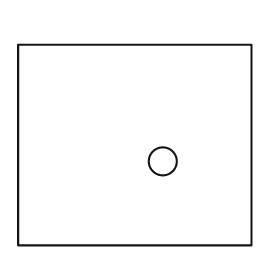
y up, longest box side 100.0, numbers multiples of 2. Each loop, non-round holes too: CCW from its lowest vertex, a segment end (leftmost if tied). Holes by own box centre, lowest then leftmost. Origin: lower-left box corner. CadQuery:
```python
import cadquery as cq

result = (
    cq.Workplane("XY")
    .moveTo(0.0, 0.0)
    .lineTo(100.0, 0.0)
    .lineTo(100.0, 86.0)
    .lineTo(0.0, 86.0)
    .close()
    .moveTo(62.0, 36.0)
    .circle(6.0)
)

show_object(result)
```